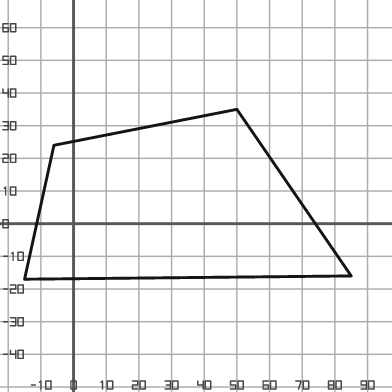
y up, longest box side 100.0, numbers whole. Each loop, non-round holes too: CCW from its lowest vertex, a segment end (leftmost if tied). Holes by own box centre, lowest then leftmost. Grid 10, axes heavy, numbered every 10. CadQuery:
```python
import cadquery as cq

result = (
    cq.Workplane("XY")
    .moveTo(-15.0, -17.0)
    .lineTo(85.0, -16.0)
    .lineTo(50.0, 35.0)
    .lineTo(-6.0, 24.0)
    .close()
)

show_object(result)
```